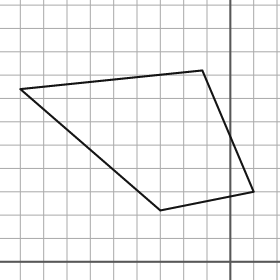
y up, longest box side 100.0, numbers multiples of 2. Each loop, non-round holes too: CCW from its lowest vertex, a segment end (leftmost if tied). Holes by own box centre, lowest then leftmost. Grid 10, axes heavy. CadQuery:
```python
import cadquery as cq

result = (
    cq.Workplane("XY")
    .moveTo(-30.0, 22.0)
    .lineTo(10.0, 30.0)
    .lineTo(-12.0, 82.0)
    .lineTo(-90.0, 74.0)
    .close()
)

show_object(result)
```